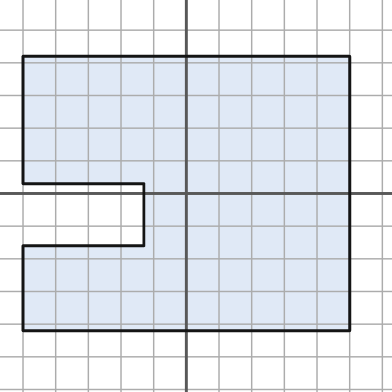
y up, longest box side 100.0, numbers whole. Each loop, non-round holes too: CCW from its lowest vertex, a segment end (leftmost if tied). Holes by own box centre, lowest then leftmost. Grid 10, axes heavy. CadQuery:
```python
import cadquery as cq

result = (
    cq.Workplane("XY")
    .moveTo(-50.0, -42.0)
    .lineTo(50.0, -42.0)
    .lineTo(50.0, 42.0)
    .lineTo(-50.0, 42.0)
    .lineTo(-50.0, 3.0)
    .lineTo(-13.0, 3.0)
    .lineTo(-13.0, -16.0)
    .lineTo(-50.0, -16.0)
    .close()
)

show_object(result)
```